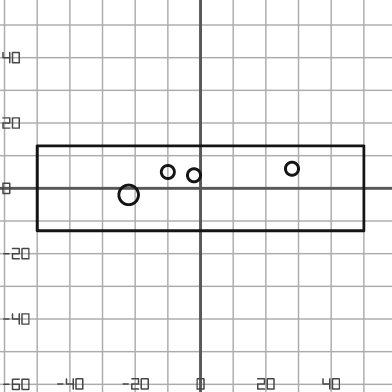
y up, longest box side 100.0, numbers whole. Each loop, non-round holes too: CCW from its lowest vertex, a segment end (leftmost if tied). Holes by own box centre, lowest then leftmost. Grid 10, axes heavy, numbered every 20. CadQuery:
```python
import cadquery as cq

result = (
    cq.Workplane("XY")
    .moveTo(-50.0, -13.0)
    .lineTo(50.0, -13.0)
    .lineTo(50.0, 13.0)
    .lineTo(-50.0, 13.0)
    .close()
    .moveTo(-22.0, -2.0)
    .circle(3.0)
    .moveTo(-2.0, 4.0)
    .circle(2.0)
    .moveTo(-10.0, 5.0)
    .circle(2.0)
    .moveTo(28.0, 6.0)
    .circle(2.0)
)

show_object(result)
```